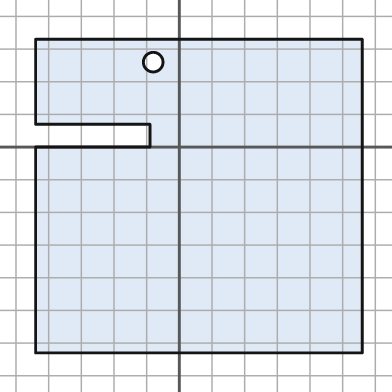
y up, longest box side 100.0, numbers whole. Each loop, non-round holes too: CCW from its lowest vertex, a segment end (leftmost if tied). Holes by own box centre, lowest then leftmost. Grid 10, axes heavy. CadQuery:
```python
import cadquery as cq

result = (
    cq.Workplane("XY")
    .moveTo(-44.0, -63.0)
    .lineTo(56.0, -63.0)
    .lineTo(56.0, 33.0)
    .lineTo(-44.0, 33.0)
    .lineTo(-44.0, 7.0)
    .lineTo(-9.0, 7.0)
    .lineTo(-9.0, 0.0)
    .lineTo(-44.0, 0.0)
    .close()
    .moveTo(-8.0, 26.0)
    .circle(3.0)
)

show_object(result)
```